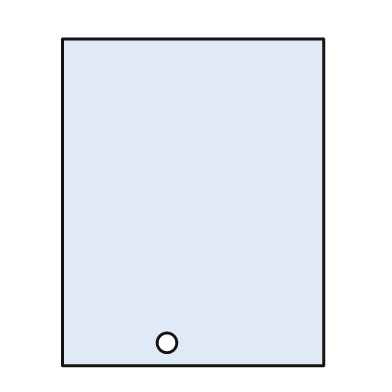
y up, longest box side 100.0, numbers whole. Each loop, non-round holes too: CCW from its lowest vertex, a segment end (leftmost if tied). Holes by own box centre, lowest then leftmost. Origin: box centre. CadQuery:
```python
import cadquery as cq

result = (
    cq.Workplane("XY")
    .moveTo(-40.0, -50.0)
    .lineTo(40.0, -50.0)
    .lineTo(40.0, 50.0)
    .lineTo(-40.0, 50.0)
    .close()
    .moveTo(-8.0, -43.0)
    .circle(3.0)
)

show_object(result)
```